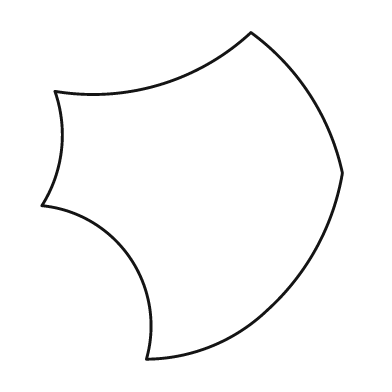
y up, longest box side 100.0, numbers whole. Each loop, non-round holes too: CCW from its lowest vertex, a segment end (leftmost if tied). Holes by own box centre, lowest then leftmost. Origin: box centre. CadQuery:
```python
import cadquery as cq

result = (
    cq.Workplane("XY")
    .moveTo(-14.0, -50.0)
    .threePointArc((6.0, -46.0), (23.0, -35.0))
    .threePointArc((38.0, -16.0), (46.0, 7.0))
    .threePointArc((36.0, 31.0), (18.0, 50.0))
    .threePointArc((-10.0, 34.0), (-42.0, 32.0))
    .threePointArc((-40.0, 14.0), (-46.0, -3.0))
    .threePointArc((-19.0, -19.0), (-14.0, -50.0))
    .close()
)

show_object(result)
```